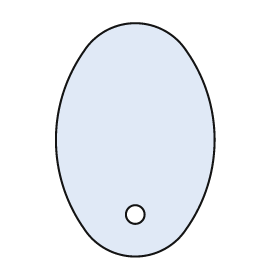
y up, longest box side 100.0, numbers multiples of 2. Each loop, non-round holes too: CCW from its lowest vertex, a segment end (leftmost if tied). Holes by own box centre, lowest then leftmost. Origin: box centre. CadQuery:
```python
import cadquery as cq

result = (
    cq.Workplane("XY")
    .moveTo(-22.0, -38.0)
    .threePointArc((0.0, -50.0), (22.0, -38.0))
    .threePointArc((34.0, 0.0), (22.0, 38.0))
    .threePointArc((0.0, 50.0), (-22.0, 38.0))
    .threePointArc((-34.0, 0.0), (-22.0, -38.0))
    .close()
    .moveTo(0.0, -32.0)
    .circle(4.0)
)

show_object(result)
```